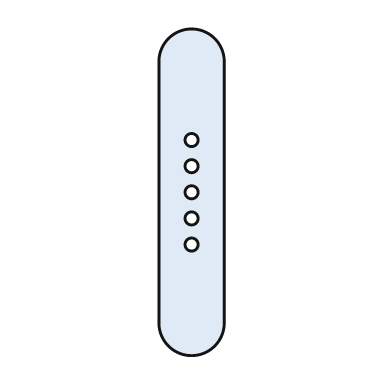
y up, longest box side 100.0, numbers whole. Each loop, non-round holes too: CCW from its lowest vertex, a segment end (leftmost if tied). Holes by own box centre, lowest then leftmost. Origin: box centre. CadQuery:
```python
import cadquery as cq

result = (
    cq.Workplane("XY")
    .moveTo(-10.0, -40.0)
    .threePointArc((0.0, -50.0), (10.0, -40.0))
    .lineTo(10.0, 40.0)
    .threePointArc((0.0, 50.0), (-10.0, 40.0))
    .close()
    .moveTo(0.0, -16.0)
    .circle(2.0)
    .moveTo(0.0, -8.0)
    .circle(2.0)
    .moveTo(0.0, 0.0)
    .circle(2.0)
    .moveTo(0.0, 8.0)
    .circle(2.0)
    .moveTo(0.0, 16.0)
    .circle(2.0)
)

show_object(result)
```